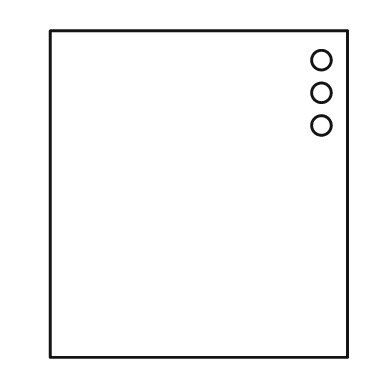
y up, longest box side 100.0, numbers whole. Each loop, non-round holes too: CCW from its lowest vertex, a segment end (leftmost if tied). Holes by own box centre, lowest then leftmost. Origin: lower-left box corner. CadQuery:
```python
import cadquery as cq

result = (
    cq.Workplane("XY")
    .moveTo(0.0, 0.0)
    .lineTo(91.0, 0.0)
    .lineTo(91.0, 100.0)
    .lineTo(0.0, 100.0)
    .close()
    .moveTo(83.0, 71.0)
    .circle(3.0)
    .moveTo(83.0, 81.0)
    .circle(3.0)
    .moveTo(83.0, 91.0)
    .circle(3.0)
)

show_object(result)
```